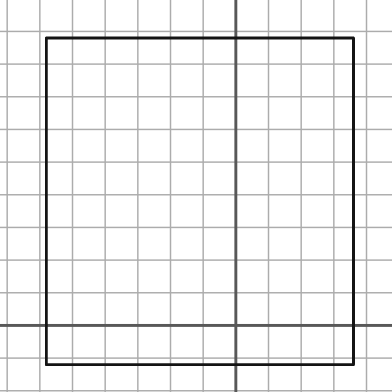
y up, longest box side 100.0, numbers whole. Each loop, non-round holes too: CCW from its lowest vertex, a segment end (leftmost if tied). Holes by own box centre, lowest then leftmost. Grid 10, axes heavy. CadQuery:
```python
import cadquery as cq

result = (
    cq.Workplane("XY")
    .moveTo(-58.0, -12.0)
    .lineTo(36.0, -12.0)
    .lineTo(36.0, 88.0)
    .lineTo(-58.0, 88.0)
    .close()
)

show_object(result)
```